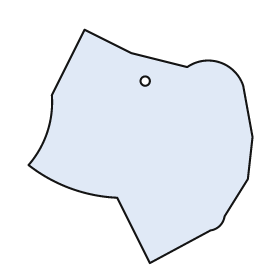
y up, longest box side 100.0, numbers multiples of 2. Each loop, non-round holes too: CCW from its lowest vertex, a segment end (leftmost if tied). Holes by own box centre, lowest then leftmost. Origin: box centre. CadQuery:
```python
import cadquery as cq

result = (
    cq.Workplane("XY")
    .moveTo(4.0, -50.0)
    .lineTo(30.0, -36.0)
    .threePointArc((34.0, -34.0), (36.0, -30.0))
    .lineTo(46.0, -14.0)
    .lineTo(48.0, 4.0)
    .lineTo(44.0, 26.0)
    .threePointArc((34.0, 36.0), (20.0, 34.0))
    .lineTo(-4.0, 40.0)
    .lineTo(-24.0, 50.0)
    .lineTo(-38.0, 22.0)
    .threePointArc((-40.0, 6.0), (-48.0, -8.0))
    .threePointArc((-30.0, -18.0), (-10.0, -22.0))
    .close()
    .moveTo(2.0, 28.0)
    .circle(2.0)
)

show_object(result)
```